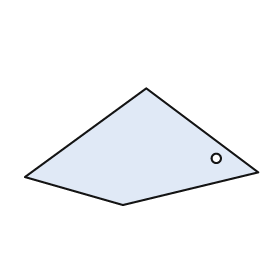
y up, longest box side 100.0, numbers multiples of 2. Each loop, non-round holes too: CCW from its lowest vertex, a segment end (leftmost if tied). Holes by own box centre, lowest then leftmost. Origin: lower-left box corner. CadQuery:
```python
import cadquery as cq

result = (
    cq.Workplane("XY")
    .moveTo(42.0, 0.0)
    .lineTo(100.0, 14.0)
    .lineTo(52.0, 50.0)
    .lineTo(0.0, 12.0)
    .close()
    .moveTo(82.0, 20.0)
    .circle(2.0)
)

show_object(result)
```